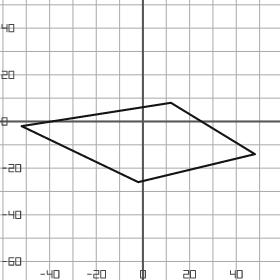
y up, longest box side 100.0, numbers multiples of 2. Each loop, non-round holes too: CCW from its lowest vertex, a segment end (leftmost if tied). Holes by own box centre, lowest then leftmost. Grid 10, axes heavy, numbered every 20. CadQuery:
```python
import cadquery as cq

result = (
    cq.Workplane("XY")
    .moveTo(-2.0, -26.0)
    .lineTo(48.0, -14.0)
    .lineTo(12.0, 8.0)
    .lineTo(-52.0, -2.0)
    .close()
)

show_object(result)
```